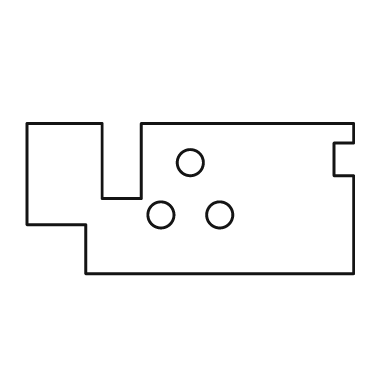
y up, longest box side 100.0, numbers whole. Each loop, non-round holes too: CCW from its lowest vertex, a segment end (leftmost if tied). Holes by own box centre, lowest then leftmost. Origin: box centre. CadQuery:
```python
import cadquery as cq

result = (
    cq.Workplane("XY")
    .moveTo(-32.0, -23.0)
    .lineTo(50.0, -23.0)
    .lineTo(50.0, 7.0)
    .lineTo(44.0, 7.0)
    .lineTo(44.0, 17.0)
    .lineTo(50.0, 17.0)
    .lineTo(50.0, 23.0)
    .lineTo(-15.0, 23.0)
    .lineTo(-15.0, 0.0)
    .lineTo(-27.0, 0.0)
    .lineTo(-27.0, 23.0)
    .lineTo(-50.0, 23.0)
    .lineTo(-50.0, -8.0)
    .lineTo(-32.0, -8.0)
    .close()
    .moveTo(-9.0, -5.0)
    .circle(4.0)
    .moveTo(9.0, -5.0)
    .circle(4.0)
    .moveTo(0.0, 11.0)
    .circle(4.0)
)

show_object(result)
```